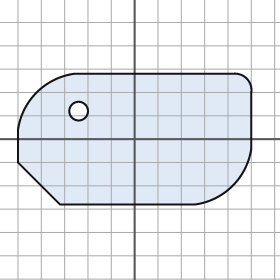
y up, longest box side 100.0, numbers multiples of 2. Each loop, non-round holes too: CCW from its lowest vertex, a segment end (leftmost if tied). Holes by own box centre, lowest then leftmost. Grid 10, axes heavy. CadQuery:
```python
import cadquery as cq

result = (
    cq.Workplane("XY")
    .moveTo(-32.0, -28.0)
    .lineTo(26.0, -28.0)
    .threePointArc((42.0, -20.0), (50.0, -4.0))
    .lineTo(50.0, 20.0)
    .threePointArc((48.0, 26.0), (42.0, 28.0))
    .lineTo(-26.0, 28.0)
    .threePointArc((-42.0, 20.0), (-50.0, 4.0))
    .lineTo(-50.0, -10.0)
    .close()
    .moveTo(-24.0, 12.0)
    .circle(4.0)
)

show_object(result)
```